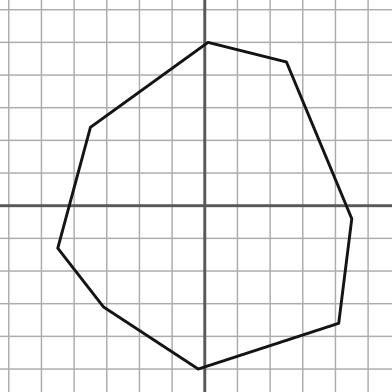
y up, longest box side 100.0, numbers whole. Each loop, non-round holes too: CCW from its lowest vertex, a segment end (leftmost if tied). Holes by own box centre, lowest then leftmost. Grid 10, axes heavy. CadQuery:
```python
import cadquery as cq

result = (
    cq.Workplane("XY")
    .moveTo(-2.0, -50.0)
    .lineTo(41.0, -36.0)
    .lineTo(45.0, -4.0)
    .lineTo(25.0, 44.0)
    .lineTo(1.0, 50.0)
    .lineTo(-35.0, 24.0)
    .lineTo(-45.0, -13.0)
    .lineTo(-31.0, -31.0)
    .close()
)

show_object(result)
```